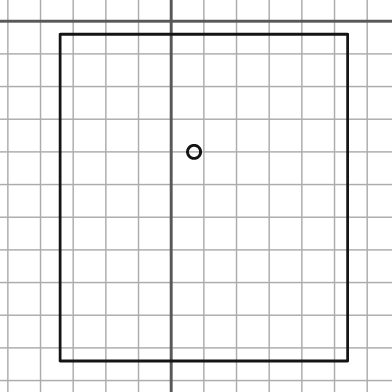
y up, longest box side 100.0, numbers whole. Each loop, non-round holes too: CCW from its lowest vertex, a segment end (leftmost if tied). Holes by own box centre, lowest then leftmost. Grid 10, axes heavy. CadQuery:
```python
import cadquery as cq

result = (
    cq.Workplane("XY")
    .moveTo(-34.0, -104.0)
    .lineTo(54.0, -104.0)
    .lineTo(54.0, -4.0)
    .lineTo(-34.0, -4.0)
    .close()
    .moveTo(7.0, -40.0)
    .circle(2.0)
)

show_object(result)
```